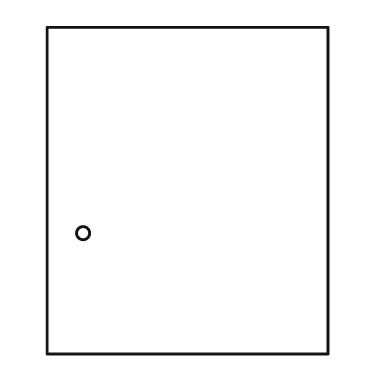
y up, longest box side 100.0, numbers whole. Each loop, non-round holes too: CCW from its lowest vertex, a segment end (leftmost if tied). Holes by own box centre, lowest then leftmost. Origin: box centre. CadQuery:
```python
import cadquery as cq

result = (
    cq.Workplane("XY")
    .moveTo(-43.0, -50.0)
    .lineTo(43.0, -50.0)
    .lineTo(43.0, 50.0)
    .lineTo(-43.0, 50.0)
    .close()
    .moveTo(-32.0, -13.0)
    .circle(2.0)
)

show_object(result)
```